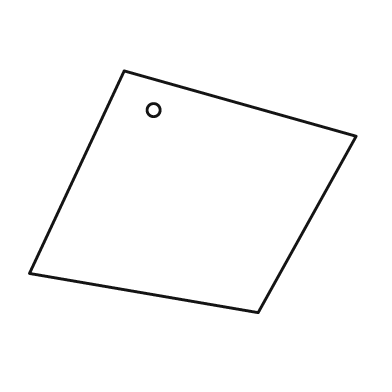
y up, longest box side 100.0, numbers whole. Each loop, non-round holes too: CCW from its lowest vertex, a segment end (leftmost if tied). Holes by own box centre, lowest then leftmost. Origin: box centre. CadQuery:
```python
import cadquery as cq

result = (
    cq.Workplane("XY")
    .moveTo(20.0, -37.0)
    .lineTo(50.0, 17.0)
    .lineTo(-21.0, 37.0)
    .lineTo(-50.0, -25.0)
    .close()
    .moveTo(-12.0, 25.0)
    .circle(2.0)
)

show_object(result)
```